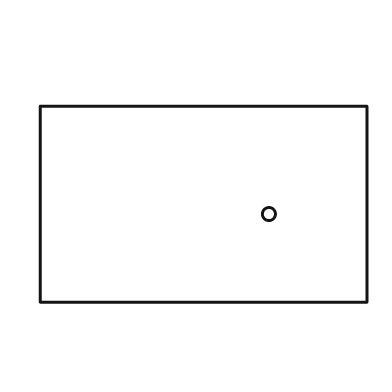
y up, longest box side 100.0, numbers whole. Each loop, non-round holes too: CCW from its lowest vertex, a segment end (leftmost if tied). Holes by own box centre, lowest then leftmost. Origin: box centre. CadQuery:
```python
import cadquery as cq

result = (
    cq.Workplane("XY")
    .moveTo(-50.0, -30.0)
    .lineTo(50.0, -30.0)
    .lineTo(50.0, 30.0)
    .lineTo(-50.0, 30.0)
    .close()
    .moveTo(20.0, -3.0)
    .circle(2.0)
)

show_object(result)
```